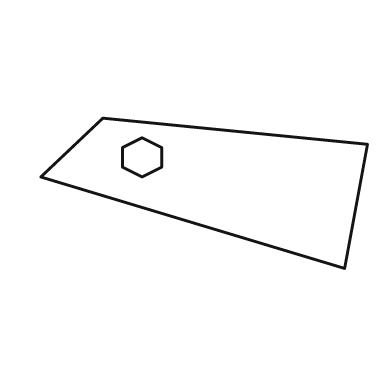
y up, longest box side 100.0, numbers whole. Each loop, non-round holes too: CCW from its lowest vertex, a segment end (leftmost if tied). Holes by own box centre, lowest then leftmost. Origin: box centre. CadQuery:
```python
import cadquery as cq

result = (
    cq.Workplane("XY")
    .moveTo(43.0, -23.0)
    .lineTo(50.0, 15.0)
    .lineTo(-31.0, 23.0)
    .lineTo(-50.0, 5.0)
    .close()
    .moveTo(-19.0, 5.0)
    .lineTo(-13.0, 8.0)
    .lineTo(-13.0, 14.0)
    .lineTo(-19.0, 17.0)
    .lineTo(-25.0, 14.0)
    .lineTo(-25.0, 8.0)
    .close()
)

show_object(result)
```